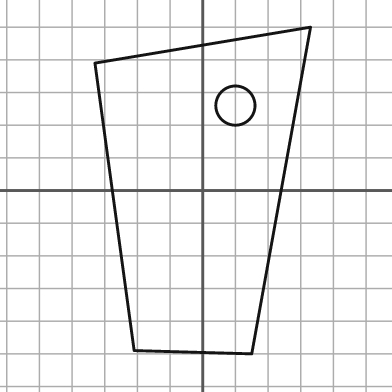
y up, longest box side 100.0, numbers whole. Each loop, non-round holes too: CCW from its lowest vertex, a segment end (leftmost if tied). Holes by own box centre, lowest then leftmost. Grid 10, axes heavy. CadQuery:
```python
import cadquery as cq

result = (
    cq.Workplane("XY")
    .moveTo(15.0, -50.0)
    .lineTo(33.0, 50.0)
    .lineTo(-33.0, 39.0)
    .lineTo(-21.0, -49.0)
    .close()
    .moveTo(10.0, 26.0)
    .circle(6.0)
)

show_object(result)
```